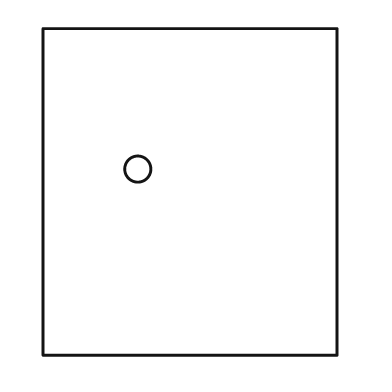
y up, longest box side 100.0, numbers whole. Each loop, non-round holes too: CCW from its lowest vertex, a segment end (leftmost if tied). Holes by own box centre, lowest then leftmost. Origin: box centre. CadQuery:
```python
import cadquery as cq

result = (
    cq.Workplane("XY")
    .moveTo(-45.0, -50.0)
    .lineTo(45.0, -50.0)
    .lineTo(45.0, 50.0)
    .lineTo(-45.0, 50.0)
    .close()
    .moveTo(-16.0, 7.0)
    .circle(4.0)
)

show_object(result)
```